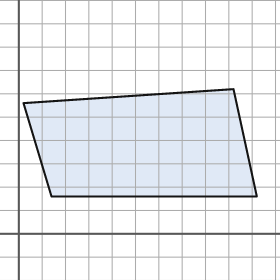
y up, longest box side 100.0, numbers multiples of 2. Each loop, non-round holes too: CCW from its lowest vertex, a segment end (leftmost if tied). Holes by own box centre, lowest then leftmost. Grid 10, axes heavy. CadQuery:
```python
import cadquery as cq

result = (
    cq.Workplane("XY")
    .moveTo(14.0, 16.0)
    .lineTo(102.0, 16.0)
    .lineTo(92.0, 62.0)
    .lineTo(2.0, 56.0)
    .close()
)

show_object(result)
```